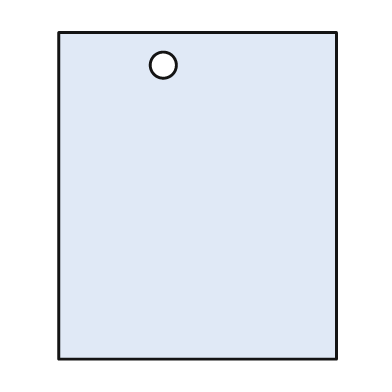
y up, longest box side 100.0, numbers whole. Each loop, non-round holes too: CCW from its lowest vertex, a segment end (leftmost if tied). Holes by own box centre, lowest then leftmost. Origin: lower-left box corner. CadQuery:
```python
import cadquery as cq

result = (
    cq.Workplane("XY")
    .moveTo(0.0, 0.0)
    .lineTo(85.0, 0.0)
    .lineTo(85.0, 100.0)
    .lineTo(0.0, 100.0)
    .close()
    .moveTo(32.0, 90.0)
    .circle(4.0)
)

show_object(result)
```